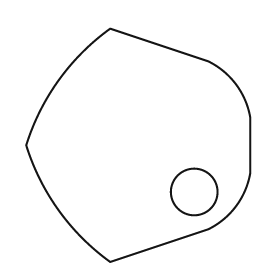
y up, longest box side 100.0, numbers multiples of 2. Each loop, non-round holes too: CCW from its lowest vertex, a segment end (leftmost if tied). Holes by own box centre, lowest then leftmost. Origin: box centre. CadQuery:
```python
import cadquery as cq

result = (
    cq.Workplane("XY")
    .moveTo(-12.0, -50.0)
    .lineTo(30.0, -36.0)
    .threePointArc((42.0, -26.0), (48.0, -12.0))
    .lineTo(48.0, 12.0)
    .threePointArc((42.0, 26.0), (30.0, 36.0))
    .lineTo(-12.0, 50.0)
    .threePointArc((-34.0, 28.0), (-48.0, 0.0))
    .threePointArc((-34.0, -28.0), (-12.0, -50.0))
    .close()
    .moveTo(24.0, -20.0)
    .circle(10.0)
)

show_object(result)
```